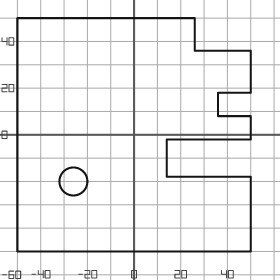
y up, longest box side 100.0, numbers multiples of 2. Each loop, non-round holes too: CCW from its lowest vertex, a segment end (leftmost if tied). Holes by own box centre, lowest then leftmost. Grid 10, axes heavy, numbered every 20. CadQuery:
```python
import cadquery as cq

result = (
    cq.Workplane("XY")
    .moveTo(-50.0, -50.0)
    .lineTo(50.0, -50.0)
    .lineTo(50.0, -18.0)
    .lineTo(14.0, -18.0)
    .lineTo(14.0, -2.0)
    .lineTo(50.0, -2.0)
    .lineTo(50.0, 8.0)
    .lineTo(36.0, 8.0)
    .lineTo(36.0, 18.0)
    .lineTo(50.0, 18.0)
    .lineTo(50.0, 36.0)
    .lineTo(26.0, 36.0)
    .lineTo(26.0, 50.0)
    .lineTo(-50.0, 50.0)
    .close()
    .moveTo(-26.0, -20.0)
    .circle(6.0)
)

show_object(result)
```